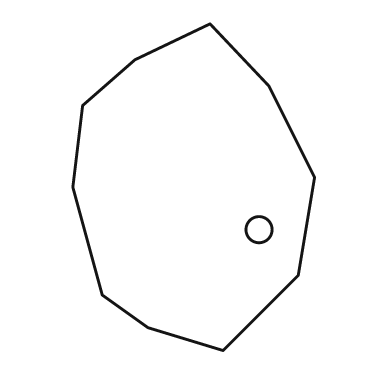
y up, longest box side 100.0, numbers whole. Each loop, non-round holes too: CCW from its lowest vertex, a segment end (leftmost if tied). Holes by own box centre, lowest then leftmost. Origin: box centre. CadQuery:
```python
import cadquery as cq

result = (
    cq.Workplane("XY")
    .moveTo(9.0, -50.0)
    .lineTo(32.0, -27.0)
    .lineTo(37.0, 3.0)
    .lineTo(23.0, 31.0)
    .lineTo(5.0, 50.0)
    .lineTo(-18.0, 39.0)
    .lineTo(-34.0, 25.0)
    .lineTo(-37.0, 0.0)
    .lineTo(-28.0, -33.0)
    .lineTo(-14.0, -43.0)
    .close()
    .moveTo(20.0, -13.0)
    .circle(4.0)
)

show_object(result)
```